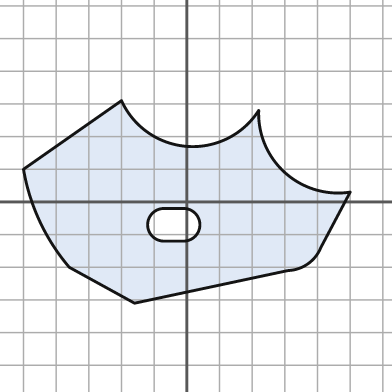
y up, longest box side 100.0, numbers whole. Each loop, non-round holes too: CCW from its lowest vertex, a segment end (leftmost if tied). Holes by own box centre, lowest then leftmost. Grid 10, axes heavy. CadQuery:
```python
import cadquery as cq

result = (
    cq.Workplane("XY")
    .moveTo(-16.0, -31.0)
    .lineTo(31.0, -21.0)
    .threePointArc((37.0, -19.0), (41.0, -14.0))
    .lineTo(50.0, 3.0)
    .threePointArc((30.0, 9.0), (22.0, 28.0))
    .threePointArc((0.0, 17.0), (-20.0, 31.0))
    .lineTo(-50.0, 10.0)
    .threePointArc((-45.0, -6.0), (-36.0, -20.0))
    .close()
    .moveTo(-7.0, -12.0)
    .lineTo(-1.0, -12.0)
    .threePointArc((4.0, -7.0), (-1.0, -2.0))
    .lineTo(-7.0, -2.0)
    .threePointArc((-12.0, -7.0), (-7.0, -12.0))
    .close()
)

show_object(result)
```